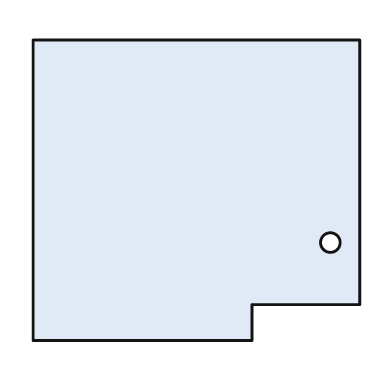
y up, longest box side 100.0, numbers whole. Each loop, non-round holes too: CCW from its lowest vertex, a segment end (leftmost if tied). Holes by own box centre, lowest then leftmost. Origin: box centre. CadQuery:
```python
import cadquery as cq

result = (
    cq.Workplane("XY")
    .moveTo(-50.0, -46.0)
    .lineTo(17.0, -46.0)
    .lineTo(17.0, -35.0)
    .lineTo(50.0, -35.0)
    .lineTo(50.0, 46.0)
    .lineTo(-50.0, 46.0)
    .close()
    .moveTo(41.0, -16.0)
    .circle(3.0)
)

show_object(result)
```